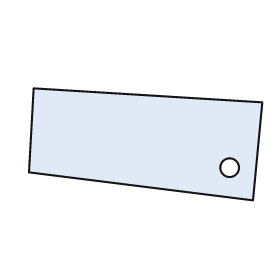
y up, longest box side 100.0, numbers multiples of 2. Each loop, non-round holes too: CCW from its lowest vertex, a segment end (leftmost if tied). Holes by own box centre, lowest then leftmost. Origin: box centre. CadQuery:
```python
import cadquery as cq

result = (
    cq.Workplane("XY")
    .moveTo(46.0, -24.0)
    .lineTo(50.0, 18.0)
    .lineTo(-48.0, 24.0)
    .lineTo(-50.0, -12.0)
    .close()
    .moveTo(36.0, -10.0)
    .circle(4.0)
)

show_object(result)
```